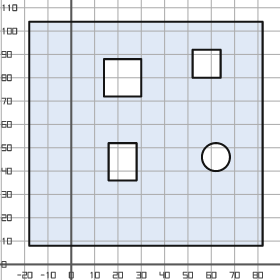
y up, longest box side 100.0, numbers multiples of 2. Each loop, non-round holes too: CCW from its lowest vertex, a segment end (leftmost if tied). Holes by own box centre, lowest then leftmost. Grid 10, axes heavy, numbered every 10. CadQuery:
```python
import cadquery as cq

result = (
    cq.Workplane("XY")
    .moveTo(-18.0, 8.0)
    .lineTo(82.0, 8.0)
    .lineTo(82.0, 104.0)
    .lineTo(-18.0, 104.0)
    .close()
    .moveTo(16.0, 36.0)
    .lineTo(28.0, 36.0)
    .lineTo(28.0, 52.0)
    .lineTo(16.0, 52.0)
    .close()
    .moveTo(62.0, 46.0)
    .circle(6.0)
    .moveTo(14.0, 72.0)
    .lineTo(30.0, 72.0)
    .lineTo(30.0, 88.0)
    .lineTo(14.0, 88.0)
    .close()
    .moveTo(52.0, 80.0)
    .lineTo(64.0, 80.0)
    .lineTo(64.0, 92.0)
    .lineTo(52.0, 92.0)
    .close()
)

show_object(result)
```